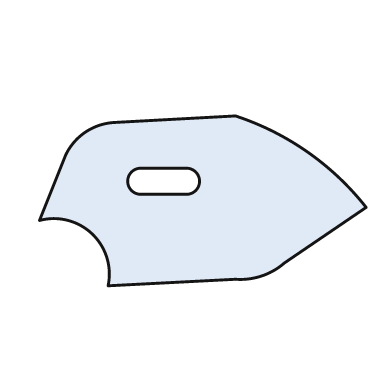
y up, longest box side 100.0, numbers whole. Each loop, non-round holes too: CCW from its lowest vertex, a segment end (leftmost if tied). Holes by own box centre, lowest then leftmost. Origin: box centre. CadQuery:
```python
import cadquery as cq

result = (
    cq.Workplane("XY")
    .moveTo(-29.0, -26.0)
    .lineTo(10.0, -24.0)
    .threePointArc((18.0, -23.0), (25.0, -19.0))
    .lineTo(50.0, -2.0)
    .threePointArc((32.0, 15.0), (10.0, 26.0))
    .lineTo(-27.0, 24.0)
    .threePointArc((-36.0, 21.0), (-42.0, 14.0))
    .lineTo(-50.0, -6.0)
    .threePointArc((-34.0, -10.0), (-29.0, -26.0))
    .close()
    .moveTo(-19.0, 2.0)
    .lineTo(-5.0, 2.0)
    .threePointArc((-1.0, 6.0), (-5.0, 10.0))
    .lineTo(-19.0, 10.0)
    .threePointArc((-23.0, 6.0), (-19.0, 2.0))
    .close()
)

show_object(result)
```